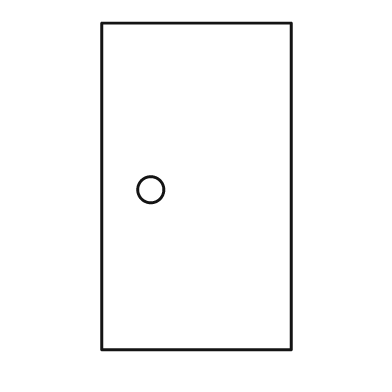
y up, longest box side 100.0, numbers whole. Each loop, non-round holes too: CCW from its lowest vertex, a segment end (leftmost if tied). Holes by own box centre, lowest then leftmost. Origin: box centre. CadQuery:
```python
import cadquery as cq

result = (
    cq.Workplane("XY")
    .moveTo(-29.0, -50.0)
    .lineTo(29.0, -50.0)
    .lineTo(29.0, 50.0)
    .lineTo(-29.0, 50.0)
    .close()
    .moveTo(-14.0, -1.0)
    .circle(4.0)
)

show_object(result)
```